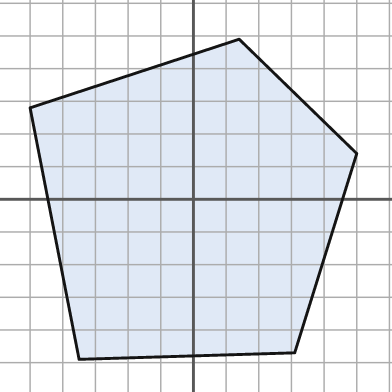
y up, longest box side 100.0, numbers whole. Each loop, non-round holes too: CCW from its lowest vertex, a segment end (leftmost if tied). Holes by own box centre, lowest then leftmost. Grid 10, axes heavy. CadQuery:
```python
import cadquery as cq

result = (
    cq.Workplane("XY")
    .moveTo(-35.0, -49.0)
    .lineTo(31.0, -47.0)
    .lineTo(50.0, 14.0)
    .lineTo(14.0, 49.0)
    .lineTo(-50.0, 28.0)
    .close()
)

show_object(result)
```